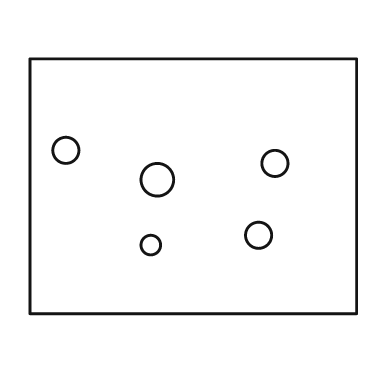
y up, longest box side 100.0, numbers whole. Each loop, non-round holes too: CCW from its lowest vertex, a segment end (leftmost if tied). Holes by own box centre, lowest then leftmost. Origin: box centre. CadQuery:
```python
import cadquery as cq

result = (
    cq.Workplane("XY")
    .moveTo(-50.0, -39.0)
    .lineTo(50.0, -39.0)
    .lineTo(50.0, 39.0)
    .lineTo(-50.0, 39.0)
    .close()
    .moveTo(-13.0, -18.0)
    .circle(3.0)
    .moveTo(20.0, -15.0)
    .circle(4.0)
    .moveTo(-11.0, 2.0)
    .circle(5.0)
    .moveTo(25.0, 7.0)
    .circle(4.0)
    .moveTo(-39.0, 11.0)
    .circle(4.0)
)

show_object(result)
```